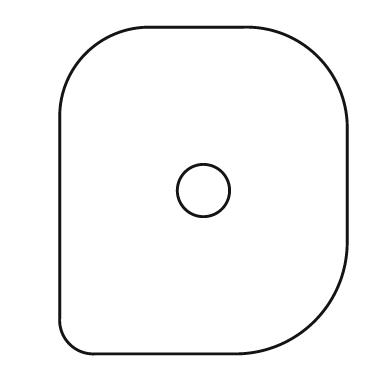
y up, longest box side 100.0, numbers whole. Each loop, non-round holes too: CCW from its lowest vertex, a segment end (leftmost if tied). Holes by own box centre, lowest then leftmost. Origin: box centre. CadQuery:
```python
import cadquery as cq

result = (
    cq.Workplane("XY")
    .moveTo(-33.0, -50.0)
    .lineTo(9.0, -50.0)
    .threePointArc((34.0, -40.0), (44.0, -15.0))
    .lineTo(44.0, 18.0)
    .threePointArc((35.0, 41.0), (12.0, 50.0))
    .lineTo(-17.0, 50.0)
    .threePointArc((-36.0, 42.0), (-44.0, 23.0))
    .lineTo(-44.0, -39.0)
    .threePointArc((-41.0, -47.0), (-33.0, -50.0))
    .close()
    .moveTo(0.0, 0.0)
    .circle(8.0)
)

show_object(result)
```